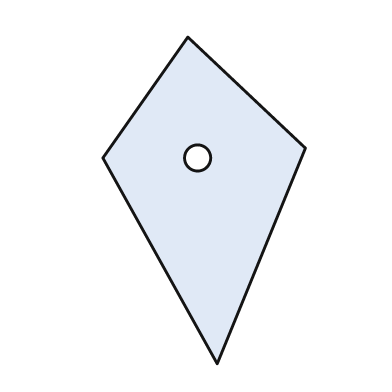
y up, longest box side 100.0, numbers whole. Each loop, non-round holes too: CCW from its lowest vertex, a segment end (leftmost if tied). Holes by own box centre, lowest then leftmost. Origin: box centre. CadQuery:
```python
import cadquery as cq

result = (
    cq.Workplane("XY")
    .moveTo(4.0, -50.0)
    .lineTo(31.0, 16.0)
    .lineTo(-5.0, 50.0)
    .lineTo(-31.0, 13.0)
    .close()
    .moveTo(-2.0, 13.0)
    .circle(4.0)
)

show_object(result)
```